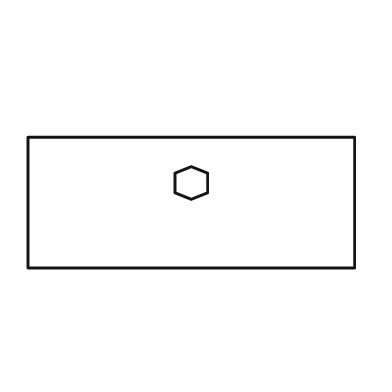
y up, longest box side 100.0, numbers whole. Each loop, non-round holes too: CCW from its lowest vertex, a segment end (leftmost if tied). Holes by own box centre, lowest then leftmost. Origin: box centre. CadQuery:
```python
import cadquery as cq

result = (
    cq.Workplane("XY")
    .moveTo(-50.0, -20.0)
    .lineTo(50.0, -20.0)
    .lineTo(50.0, 20.0)
    .lineTo(-50.0, 20.0)
    .close()
    .moveTo(0.0, 1.0)
    .lineTo(5.0, 3.0)
    .lineTo(5.0, 9.0)
    .lineTo(0.0, 11.0)
    .lineTo(-5.0, 9.0)
    .lineTo(-5.0, 3.0)
    .close()
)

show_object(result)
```